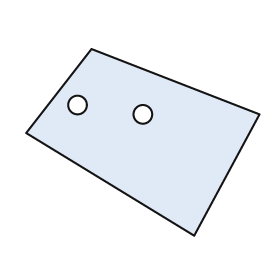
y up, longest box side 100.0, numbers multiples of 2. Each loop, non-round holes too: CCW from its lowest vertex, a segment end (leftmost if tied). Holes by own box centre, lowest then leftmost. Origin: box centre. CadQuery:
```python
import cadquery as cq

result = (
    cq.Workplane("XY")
    .moveTo(22.0, -40.0)
    .lineTo(50.0, 12.0)
    .lineTo(-22.0, 40.0)
    .lineTo(-50.0, 4.0)
    .close()
    .moveTo(0.0, 12.0)
    .circle(4.0)
    .moveTo(-28.0, 16.0)
    .circle(4.0)
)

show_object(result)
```